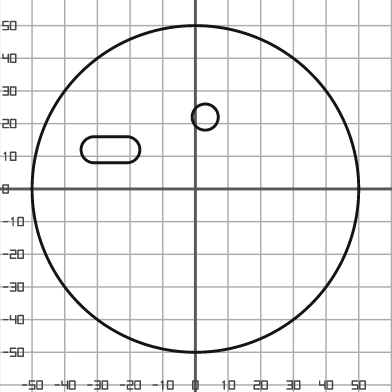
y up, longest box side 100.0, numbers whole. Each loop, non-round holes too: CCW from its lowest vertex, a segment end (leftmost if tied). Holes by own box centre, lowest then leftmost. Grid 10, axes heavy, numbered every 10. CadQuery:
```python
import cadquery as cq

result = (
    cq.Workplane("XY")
    .moveTo(0.0, 0.0)
    .circle(50.0)
    .moveTo(-31.0, 8.0)
    .lineTo(-21.0, 8.0)
    .threePointArc((-17.0, 12.0), (-21.0, 16.0))
    .lineTo(-31.0, 16.0)
    .threePointArc((-35.0, 12.0), (-31.0, 8.0))
    .close()
    .moveTo(3.0, 22.0)
    .circle(4.0)
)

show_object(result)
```